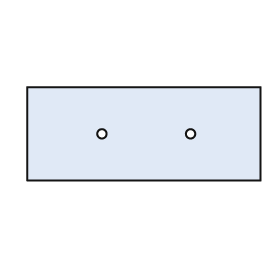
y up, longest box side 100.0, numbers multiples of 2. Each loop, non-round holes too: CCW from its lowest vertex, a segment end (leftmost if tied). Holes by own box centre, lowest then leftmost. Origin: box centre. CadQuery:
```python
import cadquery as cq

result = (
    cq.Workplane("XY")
    .moveTo(-50.0, -20.0)
    .lineTo(50.0, -20.0)
    .lineTo(50.0, 20.0)
    .lineTo(-50.0, 20.0)
    .close()
    .moveTo(-18.0, 0.0)
    .circle(2.0)
    .moveTo(20.0, 0.0)
    .circle(2.0)
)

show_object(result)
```